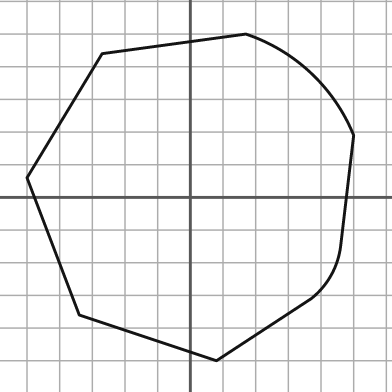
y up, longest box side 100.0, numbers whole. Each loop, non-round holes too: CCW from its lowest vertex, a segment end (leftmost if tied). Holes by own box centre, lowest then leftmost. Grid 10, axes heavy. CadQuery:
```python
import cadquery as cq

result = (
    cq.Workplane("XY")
    .moveTo(8.0, -50.0)
    .lineTo(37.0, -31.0)
    .threePointArc((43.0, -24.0), (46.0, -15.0))
    .lineTo(50.0, 19.0)
    .threePointArc((37.0, 38.0), (17.0, 50.0))
    .lineTo(-27.0, 44.0)
    .lineTo(-50.0, 6.0)
    .lineTo(-34.0, -36.0)
    .close()
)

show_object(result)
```